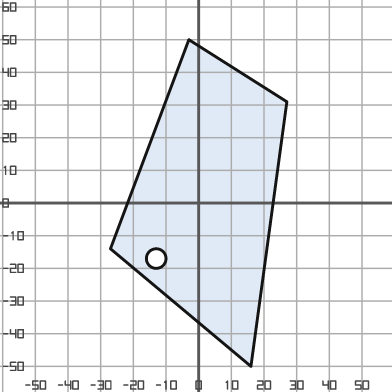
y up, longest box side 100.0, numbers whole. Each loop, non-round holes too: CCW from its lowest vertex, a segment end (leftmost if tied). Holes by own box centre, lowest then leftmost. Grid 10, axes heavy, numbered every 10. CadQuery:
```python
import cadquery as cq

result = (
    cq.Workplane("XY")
    .moveTo(16.0, -50.0)
    .lineTo(27.0, 31.0)
    .lineTo(-3.0, 50.0)
    .lineTo(-27.0, -14.0)
    .close()
    .moveTo(-13.0, -17.0)
    .circle(3.0)
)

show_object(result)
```